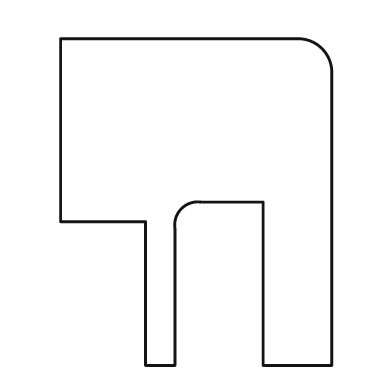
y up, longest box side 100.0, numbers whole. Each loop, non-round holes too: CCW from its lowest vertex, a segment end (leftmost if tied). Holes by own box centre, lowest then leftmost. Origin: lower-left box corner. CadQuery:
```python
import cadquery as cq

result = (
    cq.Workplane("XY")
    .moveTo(26.0, 0.0)
    .lineTo(35.0, 0.0)
    .lineTo(35.0, 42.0)
    .threePointArc((37.0, 48.0), (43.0, 50.0))
    .lineTo(62.0, 50.0)
    .lineTo(62.0, 0.0)
    .lineTo(83.0, 0.0)
    .lineTo(83.0, 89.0)
    .threePointArc((80.0, 97.0), (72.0, 100.0))
    .lineTo(0.0, 100.0)
    .lineTo(0.0, 44.0)
    .lineTo(26.0, 44.0)
    .close()
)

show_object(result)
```